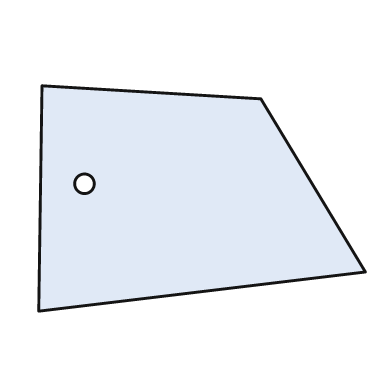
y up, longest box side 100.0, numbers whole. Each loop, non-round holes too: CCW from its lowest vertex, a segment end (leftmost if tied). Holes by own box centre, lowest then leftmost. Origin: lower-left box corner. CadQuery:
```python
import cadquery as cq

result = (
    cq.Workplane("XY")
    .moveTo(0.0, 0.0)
    .lineTo(100.0, 12.0)
    .lineTo(68.0, 65.0)
    .lineTo(1.0, 69.0)
    .close()
    .moveTo(14.0, 39.0)
    .circle(3.0)
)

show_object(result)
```